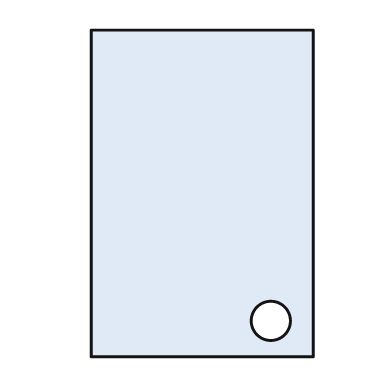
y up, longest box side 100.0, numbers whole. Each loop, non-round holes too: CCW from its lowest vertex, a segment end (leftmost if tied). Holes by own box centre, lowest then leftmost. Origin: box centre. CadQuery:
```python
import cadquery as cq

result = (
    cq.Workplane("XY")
    .moveTo(-34.0, -50.0)
    .lineTo(34.0, -50.0)
    .lineTo(34.0, 50.0)
    .lineTo(-34.0, 50.0)
    .close()
    .moveTo(21.0, -39.0)
    .circle(6.0)
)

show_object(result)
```